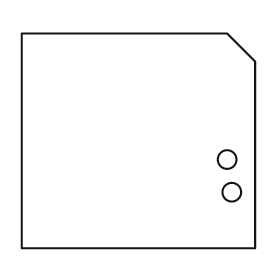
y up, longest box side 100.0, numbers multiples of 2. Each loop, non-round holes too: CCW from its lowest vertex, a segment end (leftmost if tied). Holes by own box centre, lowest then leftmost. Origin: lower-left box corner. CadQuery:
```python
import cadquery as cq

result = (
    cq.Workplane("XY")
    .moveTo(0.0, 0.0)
    .lineTo(100.0, 0.0)
    .lineTo(100.0, 80.0)
    .lineTo(88.0, 92.0)
    .lineTo(0.0, 92.0)
    .close()
    .moveTo(90.0, 24.0)
    .circle(4.0)
    .moveTo(88.0, 38.0)
    .circle(4.0)
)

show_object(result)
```